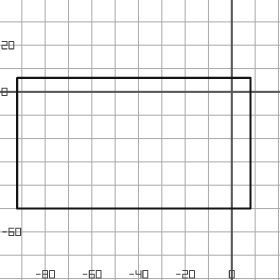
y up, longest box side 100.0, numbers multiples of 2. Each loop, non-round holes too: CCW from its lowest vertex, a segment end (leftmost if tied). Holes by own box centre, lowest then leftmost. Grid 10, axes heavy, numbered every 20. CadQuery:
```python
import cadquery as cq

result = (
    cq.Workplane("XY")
    .moveTo(-92.0, -50.0)
    .lineTo(8.0, -50.0)
    .lineTo(8.0, 6.0)
    .lineTo(-92.0, 6.0)
    .close()
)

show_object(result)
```